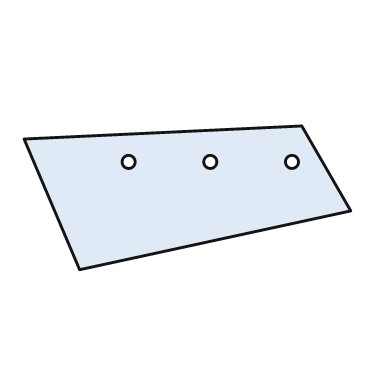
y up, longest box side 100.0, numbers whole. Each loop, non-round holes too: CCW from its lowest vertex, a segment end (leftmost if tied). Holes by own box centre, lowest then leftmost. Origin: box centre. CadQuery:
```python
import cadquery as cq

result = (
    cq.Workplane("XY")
    .moveTo(-33.0, -22.0)
    .lineTo(50.0, -4.0)
    .lineTo(35.0, 22.0)
    .lineTo(-50.0, 18.0)
    .close()
    .moveTo(-18.0, 11.0)
    .circle(2.0)
    .moveTo(7.0, 11.0)
    .circle(2.0)
    .moveTo(32.0, 11.0)
    .circle(2.0)
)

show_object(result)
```